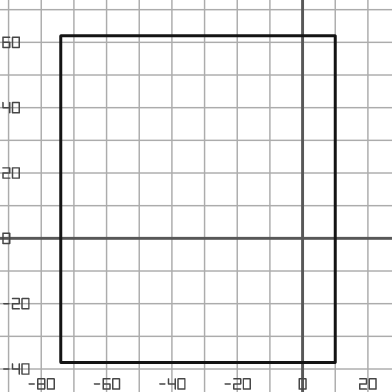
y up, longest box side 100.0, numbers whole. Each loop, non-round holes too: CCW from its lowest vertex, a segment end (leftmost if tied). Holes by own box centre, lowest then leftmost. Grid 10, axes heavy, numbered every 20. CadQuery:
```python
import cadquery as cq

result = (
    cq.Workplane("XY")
    .moveTo(-74.0, -38.0)
    .lineTo(10.0, -38.0)
    .lineTo(10.0, 62.0)
    .lineTo(-74.0, 62.0)
    .close()
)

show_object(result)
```